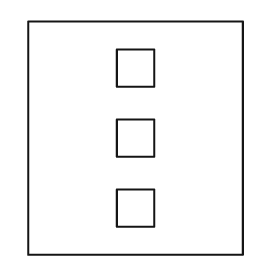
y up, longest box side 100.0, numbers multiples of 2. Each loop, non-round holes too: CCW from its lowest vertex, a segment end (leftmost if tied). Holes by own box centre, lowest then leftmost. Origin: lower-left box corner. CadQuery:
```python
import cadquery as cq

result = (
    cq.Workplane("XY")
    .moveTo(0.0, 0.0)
    .lineTo(92.0, 0.0)
    .lineTo(92.0, 100.0)
    .lineTo(0.0, 100.0)
    .close()
    .moveTo(38.0, 12.0)
    .lineTo(54.0, 12.0)
    .lineTo(54.0, 28.0)
    .lineTo(38.0, 28.0)
    .close()
    .moveTo(38.0, 42.0)
    .lineTo(54.0, 42.0)
    .lineTo(54.0, 58.0)
    .lineTo(38.0, 58.0)
    .close()
    .moveTo(38.0, 72.0)
    .lineTo(54.0, 72.0)
    .lineTo(54.0, 88.0)
    .lineTo(38.0, 88.0)
    .close()
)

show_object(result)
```